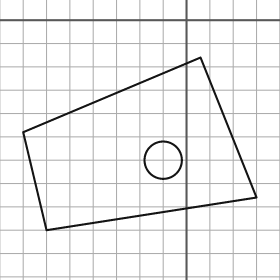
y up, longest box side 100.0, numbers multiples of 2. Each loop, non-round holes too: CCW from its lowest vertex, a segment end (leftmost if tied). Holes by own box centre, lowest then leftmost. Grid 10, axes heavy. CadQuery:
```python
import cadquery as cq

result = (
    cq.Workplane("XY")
    .moveTo(-60.0, -90.0)
    .lineTo(30.0, -76.0)
    .lineTo(6.0, -16.0)
    .lineTo(-70.0, -48.0)
    .close()
    .moveTo(-10.0, -60.0)
    .circle(8.0)
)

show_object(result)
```